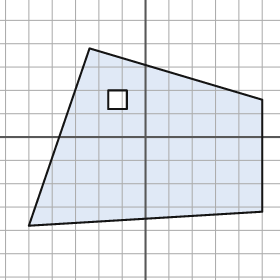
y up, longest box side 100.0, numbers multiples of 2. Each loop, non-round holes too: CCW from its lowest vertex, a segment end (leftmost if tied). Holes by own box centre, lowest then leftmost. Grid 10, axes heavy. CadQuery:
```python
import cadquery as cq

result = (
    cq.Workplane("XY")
    .moveTo(-50.0, -38.0)
    .lineTo(50.0, -32.0)
    .lineTo(50.0, 16.0)
    .lineTo(-24.0, 38.0)
    .close()
    .moveTo(-16.0, 12.0)
    .lineTo(-8.0, 12.0)
    .lineTo(-8.0, 20.0)
    .lineTo(-16.0, 20.0)
    .close()
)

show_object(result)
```